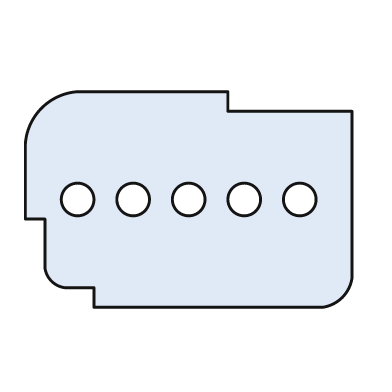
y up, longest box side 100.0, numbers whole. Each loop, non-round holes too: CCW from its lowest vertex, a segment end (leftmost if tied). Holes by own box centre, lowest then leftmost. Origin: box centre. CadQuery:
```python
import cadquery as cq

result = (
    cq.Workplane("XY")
    .moveTo(-29.0, -33.0)
    .lineTo(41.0, -33.0)
    .threePointArc((47.0, -30.0), (50.0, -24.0))
    .lineTo(50.0, 27.0)
    .lineTo(12.0, 27.0)
    .lineTo(12.0, 33.0)
    .lineTo(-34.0, 33.0)
    .threePointArc((-45.0, 28.0), (-50.0, 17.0))
    .lineTo(-50.0, -6.0)
    .lineTo(-44.0, -6.0)
    .lineTo(-44.0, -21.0)
    .threePointArc((-42.0, -25.0), (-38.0, -27.0))
    .lineTo(-29.0, -27.0)
    .close()
    .moveTo(-34.0, 0.0)
    .circle(5.0)
    .moveTo(-17.0, 0.0)
    .circle(5.0)
    .moveTo(0.0, 0.0)
    .circle(5.0)
    .moveTo(17.0, 0.0)
    .circle(5.0)
    .moveTo(34.0, 0.0)
    .circle(5.0)
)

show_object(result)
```